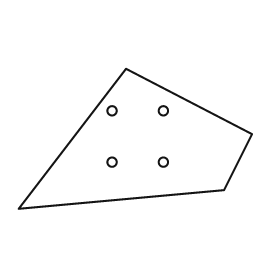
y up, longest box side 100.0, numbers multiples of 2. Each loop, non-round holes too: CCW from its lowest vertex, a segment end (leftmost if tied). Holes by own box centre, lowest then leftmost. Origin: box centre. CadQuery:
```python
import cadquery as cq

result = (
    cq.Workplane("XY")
    .moveTo(-50.0, -30.0)
    .lineTo(38.0, -22.0)
    .lineTo(50.0, 2.0)
    .lineTo(-4.0, 30.0)
    .close()
    .moveTo(-10.0, -10.0)
    .circle(2.0)
    .moveTo(12.0, -10.0)
    .circle(2.0)
    .moveTo(-10.0, 12.0)
    .circle(2.0)
    .moveTo(12.0, 12.0)
    .circle(2.0)
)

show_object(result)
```